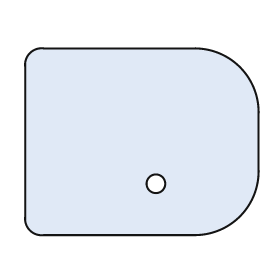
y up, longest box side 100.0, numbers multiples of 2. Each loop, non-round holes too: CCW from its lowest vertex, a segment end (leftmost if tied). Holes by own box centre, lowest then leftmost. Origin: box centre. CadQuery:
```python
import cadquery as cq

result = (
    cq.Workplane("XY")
    .moveTo(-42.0, -40.0)
    .lineTo(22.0, -40.0)
    .threePointArc((42.0, -32.0), (50.0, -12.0))
    .lineTo(50.0, 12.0)
    .threePointArc((42.0, 32.0), (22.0, 40.0))
    .lineTo(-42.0, 40.0)
    .threePointArc((-48.0, 38.0), (-50.0, 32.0))
    .lineTo(-50.0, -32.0)
    .threePointArc((-48.0, -38.0), (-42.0, -40.0))
    .close()
    .moveTo(6.0, -18.0)
    .circle(4.0)
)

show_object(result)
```